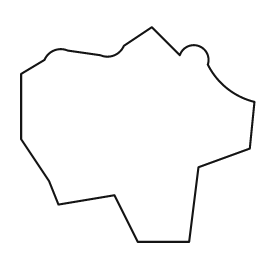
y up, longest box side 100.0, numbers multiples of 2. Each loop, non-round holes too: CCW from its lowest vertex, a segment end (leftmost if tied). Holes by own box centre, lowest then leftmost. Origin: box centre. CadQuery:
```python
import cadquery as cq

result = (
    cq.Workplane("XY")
    .moveTo(0.0, -46.0)
    .lineTo(22.0, -46.0)
    .lineTo(26.0, -14.0)
    .lineTo(48.0, -6.0)
    .lineTo(50.0, 14.0)
    .threePointArc((38.0, 20.0), (30.0, 30.0))
    .threePointArc((26.0, 38.0), (18.0, 34.0))
    .lineTo(6.0, 46.0)
    .lineTo(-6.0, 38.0)
    .threePointArc((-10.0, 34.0), (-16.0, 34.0))
    .lineTo(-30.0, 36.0)
    .threePointArc((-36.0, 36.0), (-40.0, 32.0))
    .lineTo(-50.0, 26.0)
    .lineTo(-50.0, -2.0)
    .lineTo(-38.0, -20.0)
    .lineTo(-34.0, -30.0)
    .lineTo(-10.0, -26.0)
    .close()
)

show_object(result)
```